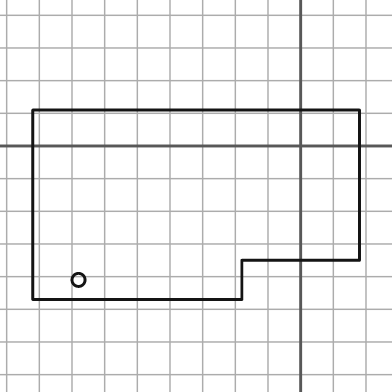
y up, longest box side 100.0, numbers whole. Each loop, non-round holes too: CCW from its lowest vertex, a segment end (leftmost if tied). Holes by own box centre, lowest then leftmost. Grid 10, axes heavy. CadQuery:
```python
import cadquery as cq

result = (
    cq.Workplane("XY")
    .moveTo(-82.0, -47.0)
    .lineTo(-18.0, -47.0)
    .lineTo(-18.0, -35.0)
    .lineTo(18.0, -35.0)
    .lineTo(18.0, 11.0)
    .lineTo(-82.0, 11.0)
    .close()
    .moveTo(-68.0, -41.0)
    .circle(2.0)
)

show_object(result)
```